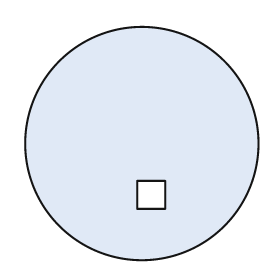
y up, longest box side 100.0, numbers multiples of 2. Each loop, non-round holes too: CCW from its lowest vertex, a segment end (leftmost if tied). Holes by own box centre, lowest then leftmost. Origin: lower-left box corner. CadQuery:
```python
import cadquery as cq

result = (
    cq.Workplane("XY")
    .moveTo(50.0, 50.0)
    .circle(50.0)
    .moveTo(48.0, 22.0)
    .lineTo(60.0, 22.0)
    .lineTo(60.0, 34.0)
    .lineTo(48.0, 34.0)
    .close()
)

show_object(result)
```